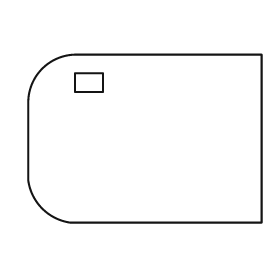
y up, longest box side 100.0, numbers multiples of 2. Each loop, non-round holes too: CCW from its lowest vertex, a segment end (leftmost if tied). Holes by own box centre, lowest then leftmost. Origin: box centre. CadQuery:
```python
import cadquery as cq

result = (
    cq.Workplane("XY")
    .moveTo(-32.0, -36.0)
    .lineTo(50.0, -36.0)
    .lineTo(50.0, 36.0)
    .lineTo(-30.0, 36.0)
    .threePointArc((-44.0, 30.0), (-50.0, 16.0))
    .lineTo(-50.0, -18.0)
    .threePointArc((-44.0, -30.0), (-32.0, -36.0))
    .close()
    .moveTo(-30.0, 20.0)
    .lineTo(-18.0, 20.0)
    .lineTo(-18.0, 28.0)
    .lineTo(-30.0, 28.0)
    .close()
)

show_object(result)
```